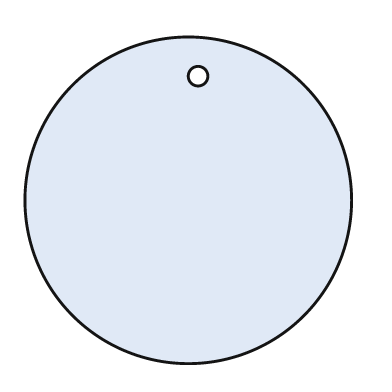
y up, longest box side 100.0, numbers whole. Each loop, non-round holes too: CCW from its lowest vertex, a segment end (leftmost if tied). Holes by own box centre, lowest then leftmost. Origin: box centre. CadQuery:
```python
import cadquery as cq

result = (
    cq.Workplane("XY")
    .moveTo(0.0, 0.0)
    .circle(50.0)
    .moveTo(3.0, 38.0)
    .circle(3.0)
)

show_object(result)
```